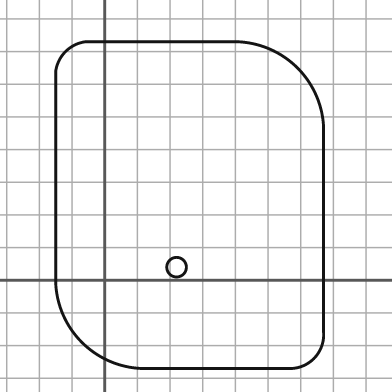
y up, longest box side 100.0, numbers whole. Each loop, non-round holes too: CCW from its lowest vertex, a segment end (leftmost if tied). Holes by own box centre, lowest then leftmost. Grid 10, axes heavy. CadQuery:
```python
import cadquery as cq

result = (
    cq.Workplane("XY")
    .moveTo(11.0, -27.0)
    .lineTo(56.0, -27.0)
    .threePointArc((64.0, -24.0), (67.0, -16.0))
    .lineTo(67.0, 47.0)
    .threePointArc((59.0, 65.0), (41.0, 73.0))
    .lineTo(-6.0, 73.0)
    .threePointArc((-12.0, 70.0), (-15.0, 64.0))
    .lineTo(-15.0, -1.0)
    .threePointArc((-7.0, -19.0), (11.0, -27.0))
    .close()
    .moveTo(22.0, 4.0)
    .circle(3.0)
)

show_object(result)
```